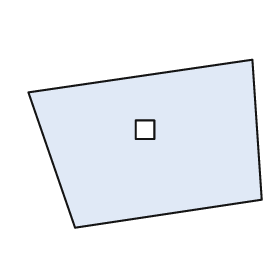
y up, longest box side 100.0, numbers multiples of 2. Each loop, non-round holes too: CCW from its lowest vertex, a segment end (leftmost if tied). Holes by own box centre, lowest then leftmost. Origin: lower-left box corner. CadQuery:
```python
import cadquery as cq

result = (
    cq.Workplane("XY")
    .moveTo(20.0, 0.0)
    .lineTo(100.0, 12.0)
    .lineTo(96.0, 72.0)
    .lineTo(0.0, 58.0)
    .close()
    .moveTo(46.0, 38.0)
    .lineTo(54.0, 38.0)
    .lineTo(54.0, 46.0)
    .lineTo(46.0, 46.0)
    .close()
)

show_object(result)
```